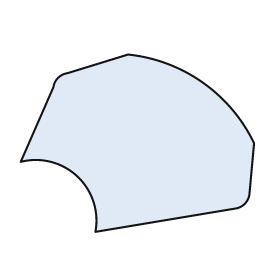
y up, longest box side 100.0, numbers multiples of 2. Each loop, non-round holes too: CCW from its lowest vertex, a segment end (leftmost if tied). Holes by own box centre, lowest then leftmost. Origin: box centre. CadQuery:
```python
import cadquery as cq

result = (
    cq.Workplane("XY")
    .moveTo(-18.0, -38.0)
    .lineTo(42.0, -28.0)
    .threePointArc((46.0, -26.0), (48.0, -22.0))
    .lineTo(50.0, 0.0)
    .threePointArc((28.0, 26.0), (-4.0, 38.0))
    .lineTo(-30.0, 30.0)
    .threePointArc((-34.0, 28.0), (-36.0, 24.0))
    .lineTo(-50.0, -8.0)
    .threePointArc((-26.0, -14.0), (-18.0, -38.0))
    .close()
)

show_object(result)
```